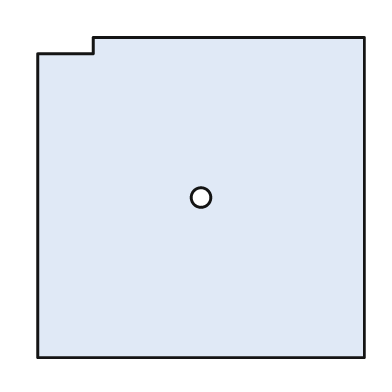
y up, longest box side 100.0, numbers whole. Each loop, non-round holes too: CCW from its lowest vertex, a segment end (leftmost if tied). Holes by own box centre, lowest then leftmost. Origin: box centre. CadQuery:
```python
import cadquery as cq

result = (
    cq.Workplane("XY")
    .moveTo(-50.0, -49.0)
    .lineTo(50.0, -49.0)
    .lineTo(50.0, 49.0)
    .lineTo(-33.0, 49.0)
    .lineTo(-33.0, 44.0)
    .lineTo(-50.0, 44.0)
    .close()
    .moveTo(0.0, 0.0)
    .circle(3.0)
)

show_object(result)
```